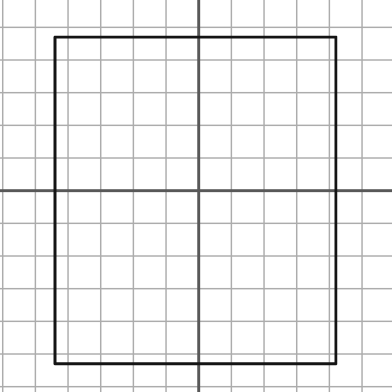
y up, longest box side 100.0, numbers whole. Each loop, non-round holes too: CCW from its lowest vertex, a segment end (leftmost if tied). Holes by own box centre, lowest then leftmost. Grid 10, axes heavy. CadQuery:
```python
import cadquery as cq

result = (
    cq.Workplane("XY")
    .moveTo(-44.0, -53.0)
    .lineTo(42.0, -53.0)
    .lineTo(42.0, 47.0)
    .lineTo(-44.0, 47.0)
    .close()
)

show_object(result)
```